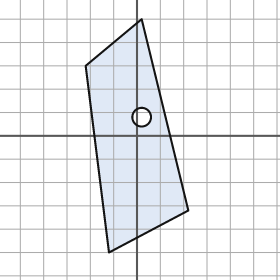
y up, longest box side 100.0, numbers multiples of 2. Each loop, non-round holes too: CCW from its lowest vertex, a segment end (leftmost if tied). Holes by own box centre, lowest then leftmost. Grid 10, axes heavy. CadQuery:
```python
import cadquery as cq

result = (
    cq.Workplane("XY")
    .moveTo(-12.0, -50.0)
    .lineTo(22.0, -32.0)
    .lineTo(2.0, 50.0)
    .lineTo(-22.0, 30.0)
    .close()
    .moveTo(2.0, 8.0)
    .circle(4.0)
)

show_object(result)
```